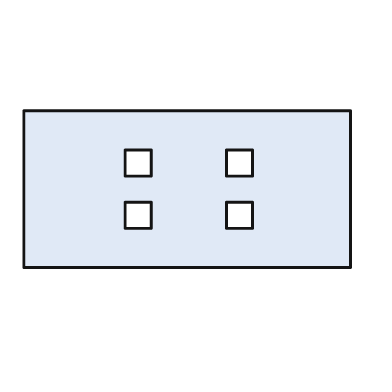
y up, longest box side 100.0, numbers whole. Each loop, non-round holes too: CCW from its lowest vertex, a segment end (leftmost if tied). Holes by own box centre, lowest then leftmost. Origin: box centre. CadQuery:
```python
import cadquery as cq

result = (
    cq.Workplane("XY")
    .moveTo(-50.0, -24.0)
    .lineTo(50.0, -24.0)
    .lineTo(50.0, 24.0)
    .lineTo(-50.0, 24.0)
    .close()
    .moveTo(-19.0, -12.0)
    .lineTo(-11.0, -12.0)
    .lineTo(-11.0, -4.0)
    .lineTo(-19.0, -4.0)
    .close()
    .moveTo(12.0, -12.0)
    .lineTo(20.0, -12.0)
    .lineTo(20.0, -4.0)
    .lineTo(12.0, -4.0)
    .close()
    .moveTo(-19.0, 4.0)
    .lineTo(-11.0, 4.0)
    .lineTo(-11.0, 12.0)
    .lineTo(-19.0, 12.0)
    .close()
    .moveTo(12.0, 4.0)
    .lineTo(20.0, 4.0)
    .lineTo(20.0, 12.0)
    .lineTo(12.0, 12.0)
    .close()
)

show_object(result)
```